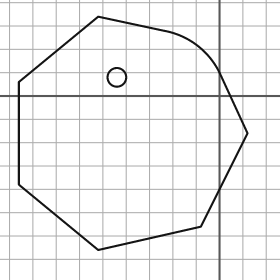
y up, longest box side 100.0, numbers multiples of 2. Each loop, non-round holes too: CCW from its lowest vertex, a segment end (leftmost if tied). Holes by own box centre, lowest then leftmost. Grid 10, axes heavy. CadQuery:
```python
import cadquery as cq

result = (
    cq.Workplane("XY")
    .moveTo(-52.0, -66.0)
    .lineTo(-8.0, -56.0)
    .lineTo(12.0, -16.0)
    .lineTo(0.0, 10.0)
    .threePointArc((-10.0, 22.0), (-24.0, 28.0))
    .lineTo(-52.0, 34.0)
    .lineTo(-86.0, 6.0)
    .lineTo(-86.0, -38.0)
    .close()
    .moveTo(-44.0, 8.0)
    .circle(4.0)
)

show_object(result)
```